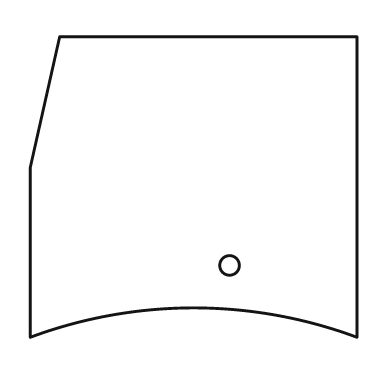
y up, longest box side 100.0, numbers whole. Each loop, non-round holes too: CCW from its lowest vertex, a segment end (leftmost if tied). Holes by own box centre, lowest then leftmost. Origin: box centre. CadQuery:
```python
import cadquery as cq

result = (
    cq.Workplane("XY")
    .moveTo(-50.0, -46.0)
    .threePointArc((0.0, -37.0), (50.0, -46.0))
    .lineTo(50.0, 46.0)
    .lineTo(-41.0, 46.0)
    .lineTo(-50.0, 6.0)
    .close()
    .moveTo(11.0, -24.0)
    .circle(3.0)
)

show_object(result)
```